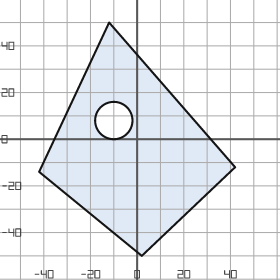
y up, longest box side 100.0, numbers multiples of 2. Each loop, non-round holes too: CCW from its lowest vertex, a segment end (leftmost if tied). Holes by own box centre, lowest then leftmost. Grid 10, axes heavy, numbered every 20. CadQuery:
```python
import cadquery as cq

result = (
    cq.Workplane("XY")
    .moveTo(2.0, -50.0)
    .lineTo(42.0, -12.0)
    .lineTo(-12.0, 50.0)
    .lineTo(-42.0, -14.0)
    .close()
    .moveTo(-10.0, 8.0)
    .circle(8.0)
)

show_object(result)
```